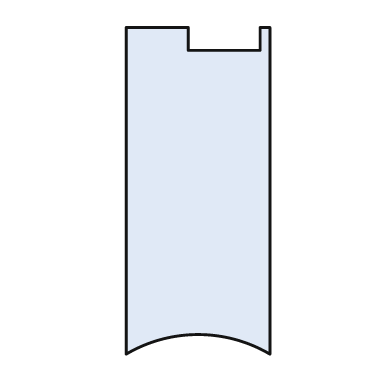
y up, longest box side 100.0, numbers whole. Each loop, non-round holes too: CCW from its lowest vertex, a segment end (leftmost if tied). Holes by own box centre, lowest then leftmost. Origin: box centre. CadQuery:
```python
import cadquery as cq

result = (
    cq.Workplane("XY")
    .moveTo(-22.0, -50.0)
    .threePointArc((0.0, -44.0), (22.0, -50.0))
    .lineTo(22.0, 50.0)
    .lineTo(19.0, 50.0)
    .lineTo(19.0, 43.0)
    .lineTo(-3.0, 43.0)
    .lineTo(-3.0, 50.0)
    .lineTo(-22.0, 50.0)
    .close()
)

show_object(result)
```